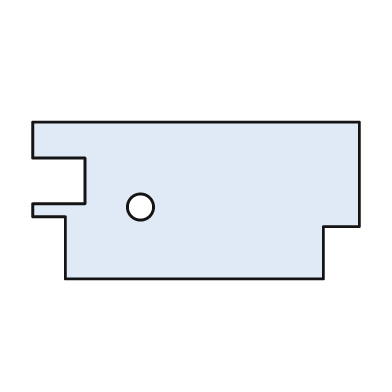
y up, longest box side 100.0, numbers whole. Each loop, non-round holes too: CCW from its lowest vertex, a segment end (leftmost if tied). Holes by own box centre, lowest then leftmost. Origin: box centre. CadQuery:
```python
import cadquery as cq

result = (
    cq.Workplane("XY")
    .moveTo(-40.0, -24.0)
    .lineTo(39.0, -24.0)
    .lineTo(39.0, -8.0)
    .lineTo(50.0, -8.0)
    .lineTo(50.0, 24.0)
    .lineTo(-50.0, 24.0)
    .lineTo(-50.0, 13.0)
    .lineTo(-34.0, 13.0)
    .lineTo(-34.0, -1.0)
    .lineTo(-50.0, -1.0)
    .lineTo(-50.0, -5.0)
    .lineTo(-40.0, -5.0)
    .close()
    .moveTo(-17.0, -2.0)
    .circle(4.0)
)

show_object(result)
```